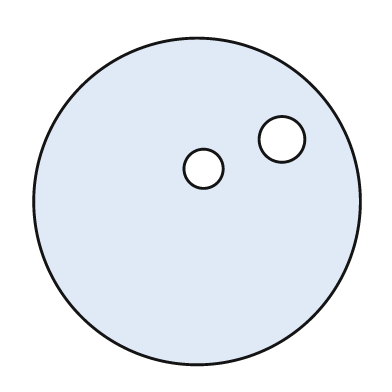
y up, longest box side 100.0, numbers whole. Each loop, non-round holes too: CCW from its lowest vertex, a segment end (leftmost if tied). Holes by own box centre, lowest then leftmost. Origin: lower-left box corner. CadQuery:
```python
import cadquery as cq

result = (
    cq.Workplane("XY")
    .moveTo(50.0, 50.0)
    .circle(50.0)
    .moveTo(52.0, 60.0)
    .circle(6.0)
    .moveTo(76.0, 69.0)
    .circle(7.0)
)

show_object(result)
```